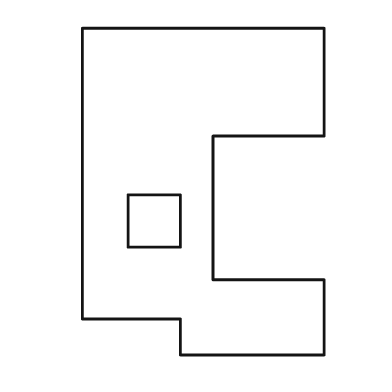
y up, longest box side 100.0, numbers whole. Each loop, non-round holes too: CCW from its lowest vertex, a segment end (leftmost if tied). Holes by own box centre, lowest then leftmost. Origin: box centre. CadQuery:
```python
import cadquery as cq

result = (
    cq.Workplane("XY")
    .moveTo(-7.0, -50.0)
    .lineTo(37.0, -50.0)
    .lineTo(37.0, -27.0)
    .lineTo(3.0, -27.0)
    .lineTo(3.0, 17.0)
    .lineTo(37.0, 17.0)
    .lineTo(37.0, 50.0)
    .lineTo(-37.0, 50.0)
    .lineTo(-37.0, -39.0)
    .lineTo(-7.0, -39.0)
    .close()
    .moveTo(-23.0, -17.0)
    .lineTo(-7.0, -17.0)
    .lineTo(-7.0, -1.0)
    .lineTo(-23.0, -1.0)
    .close()
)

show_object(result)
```